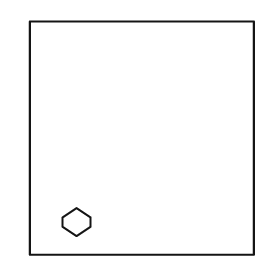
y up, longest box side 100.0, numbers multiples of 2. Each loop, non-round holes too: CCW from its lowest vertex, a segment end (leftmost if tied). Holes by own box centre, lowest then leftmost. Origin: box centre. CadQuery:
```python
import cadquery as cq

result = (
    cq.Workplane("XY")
    .moveTo(-48.0, -50.0)
    .lineTo(48.0, -50.0)
    .lineTo(48.0, 50.0)
    .lineTo(-48.0, 50.0)
    .close()
    .moveTo(-28.0, -42.0)
    .lineTo(-22.0, -38.0)
    .lineTo(-22.0, -34.0)
    .lineTo(-28.0, -30.0)
    .lineTo(-34.0, -34.0)
    .lineTo(-34.0, -38.0)
    .close()
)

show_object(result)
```